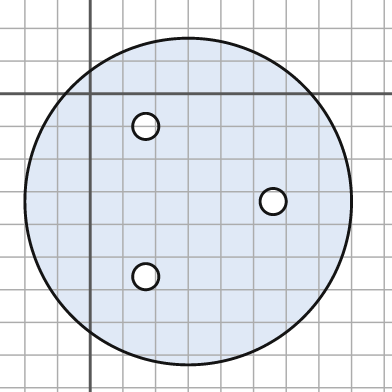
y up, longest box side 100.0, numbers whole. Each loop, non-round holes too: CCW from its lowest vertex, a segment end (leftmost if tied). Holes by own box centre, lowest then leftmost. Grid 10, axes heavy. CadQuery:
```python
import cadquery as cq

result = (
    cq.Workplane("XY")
    .moveTo(30.0, -33.0)
    .circle(50.0)
    .moveTo(17.0, -56.0)
    .circle(4.0)
    .moveTo(56.0, -33.0)
    .circle(4.0)
    .moveTo(17.0, -10.0)
    .circle(4.0)
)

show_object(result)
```